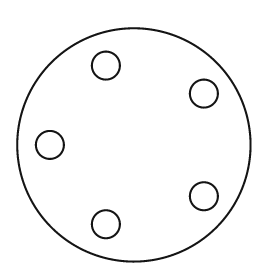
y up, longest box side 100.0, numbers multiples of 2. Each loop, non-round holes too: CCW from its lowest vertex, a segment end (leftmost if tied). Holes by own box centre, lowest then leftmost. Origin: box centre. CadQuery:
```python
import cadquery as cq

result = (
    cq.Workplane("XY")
    .moveTo(0.0, 0.0)
    .circle(50.0)
    .moveTo(-12.0, -34.0)
    .circle(6.0)
    .moveTo(30.0, -22.0)
    .circle(6.0)
    .moveTo(-36.0, 0.0)
    .circle(6.0)
    .moveTo(30.0, 22.0)
    .circle(6.0)
    .moveTo(-12.0, 34.0)
    .circle(6.0)
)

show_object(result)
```